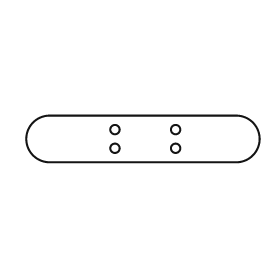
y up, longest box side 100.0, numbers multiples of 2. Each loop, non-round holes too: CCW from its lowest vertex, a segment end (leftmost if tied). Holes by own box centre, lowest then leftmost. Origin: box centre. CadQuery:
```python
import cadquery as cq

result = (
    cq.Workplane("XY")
    .moveTo(-40.0, -10.0)
    .lineTo(40.0, -10.0)
    .threePointArc((50.0, 0.0), (40.0, 10.0))
    .lineTo(-40.0, 10.0)
    .threePointArc((-50.0, 0.0), (-40.0, -10.0))
    .close()
    .moveTo(-12.0, -4.0)
    .circle(2.0)
    .moveTo(14.0, -4.0)
    .circle(2.0)
    .moveTo(-12.0, 4.0)
    .circle(2.0)
    .moveTo(14.0, 4.0)
    .circle(2.0)
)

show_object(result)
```